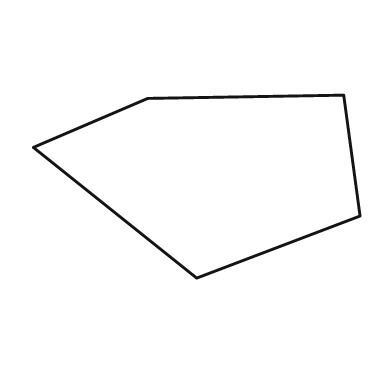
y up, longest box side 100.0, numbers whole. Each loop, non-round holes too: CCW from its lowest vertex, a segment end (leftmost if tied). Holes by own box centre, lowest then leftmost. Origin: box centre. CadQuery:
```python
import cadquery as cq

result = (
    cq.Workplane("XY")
    .moveTo(0.0, -28.0)
    .lineTo(50.0, -9.0)
    .lineTo(45.0, 28.0)
    .lineTo(-15.0, 27.0)
    .lineTo(-50.0, 12.0)
    .close()
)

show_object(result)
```